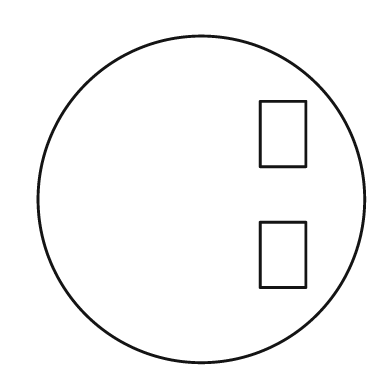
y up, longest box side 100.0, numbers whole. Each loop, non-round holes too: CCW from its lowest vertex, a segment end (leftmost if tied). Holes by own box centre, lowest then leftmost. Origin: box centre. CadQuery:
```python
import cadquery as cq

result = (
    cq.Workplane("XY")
    .moveTo(0.0, 0.0)
    .circle(50.0)
    .moveTo(18.0, -27.0)
    .lineTo(32.0, -27.0)
    .lineTo(32.0, -7.0)
    .lineTo(18.0, -7.0)
    .close()
    .moveTo(18.0, 10.0)
    .lineTo(32.0, 10.0)
    .lineTo(32.0, 30.0)
    .lineTo(18.0, 30.0)
    .close()
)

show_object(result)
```